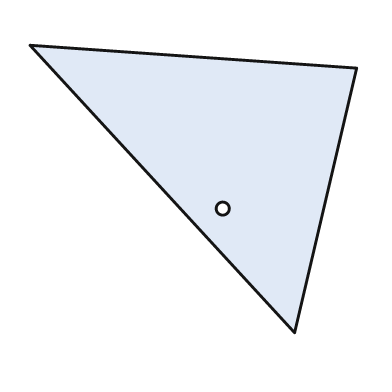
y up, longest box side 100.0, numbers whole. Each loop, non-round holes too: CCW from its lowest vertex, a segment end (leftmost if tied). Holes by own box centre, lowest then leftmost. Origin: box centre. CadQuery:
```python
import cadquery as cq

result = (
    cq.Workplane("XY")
    .moveTo(31.0, -44.0)
    .lineTo(50.0, 37.0)
    .lineTo(-50.0, 44.0)
    .close()
    .moveTo(9.0, -6.0)
    .circle(2.0)
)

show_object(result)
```